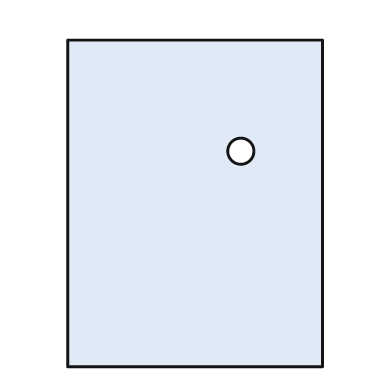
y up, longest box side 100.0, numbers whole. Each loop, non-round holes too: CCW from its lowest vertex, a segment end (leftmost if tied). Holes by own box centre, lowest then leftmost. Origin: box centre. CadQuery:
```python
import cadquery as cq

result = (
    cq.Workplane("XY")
    .moveTo(-39.0, -50.0)
    .lineTo(39.0, -50.0)
    .lineTo(39.0, 50.0)
    .lineTo(-39.0, 50.0)
    .close()
    .moveTo(14.0, 16.0)
    .circle(4.0)
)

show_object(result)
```